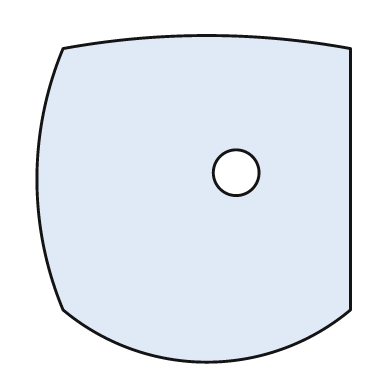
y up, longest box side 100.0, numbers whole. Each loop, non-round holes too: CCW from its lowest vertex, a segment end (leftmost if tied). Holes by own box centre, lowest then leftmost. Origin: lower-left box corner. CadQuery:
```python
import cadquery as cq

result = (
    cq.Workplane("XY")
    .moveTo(8.0, 16.0)
    .threePointArc((52.0, 0.0), (96.0, 16.0))
    .lineTo(96.0, 96.0)
    .threePointArc((52.0, 100.0), (8.0, 96.0))
    .threePointArc((0.0, 56.0), (8.0, 16.0))
    .close()
    .moveTo(61.0, 58.0)
    .circle(7.0)
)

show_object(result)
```